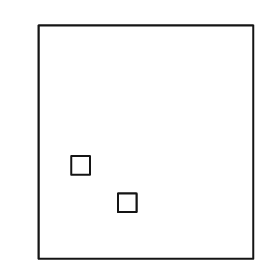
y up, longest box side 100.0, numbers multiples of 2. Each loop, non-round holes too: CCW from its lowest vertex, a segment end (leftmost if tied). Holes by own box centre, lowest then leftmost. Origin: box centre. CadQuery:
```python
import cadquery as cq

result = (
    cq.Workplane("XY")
    .moveTo(-46.0, -50.0)
    .lineTo(46.0, -50.0)
    .lineTo(46.0, 50.0)
    .lineTo(-46.0, 50.0)
    .close()
    .moveTo(-12.0, -30.0)
    .lineTo(-4.0, -30.0)
    .lineTo(-4.0, -22.0)
    .lineTo(-12.0, -22.0)
    .close()
    .moveTo(-32.0, -14.0)
    .lineTo(-24.0, -14.0)
    .lineTo(-24.0, -6.0)
    .lineTo(-32.0, -6.0)
    .close()
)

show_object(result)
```